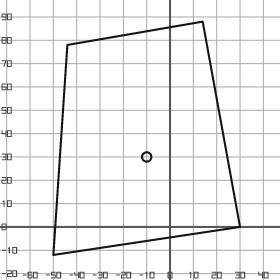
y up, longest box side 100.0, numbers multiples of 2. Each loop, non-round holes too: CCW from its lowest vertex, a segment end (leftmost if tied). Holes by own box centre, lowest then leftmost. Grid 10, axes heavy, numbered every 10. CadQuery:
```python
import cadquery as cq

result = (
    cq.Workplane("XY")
    .moveTo(-50.0, -12.0)
    .lineTo(30.0, 0.0)
    .lineTo(14.0, 88.0)
    .lineTo(-44.0, 78.0)
    .close()
    .moveTo(-10.0, 30.0)
    .circle(2.0)
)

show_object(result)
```